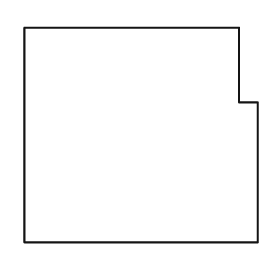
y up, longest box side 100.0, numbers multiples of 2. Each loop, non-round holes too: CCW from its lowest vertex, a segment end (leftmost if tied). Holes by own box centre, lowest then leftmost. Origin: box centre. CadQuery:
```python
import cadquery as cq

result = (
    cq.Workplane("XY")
    .moveTo(-50.0, -46.0)
    .lineTo(50.0, -46.0)
    .lineTo(50.0, 14.0)
    .lineTo(42.0, 14.0)
    .lineTo(42.0, 46.0)
    .lineTo(-50.0, 46.0)
    .close()
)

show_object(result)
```